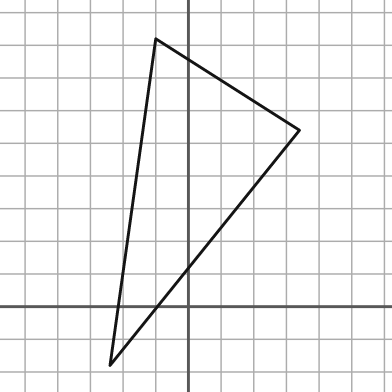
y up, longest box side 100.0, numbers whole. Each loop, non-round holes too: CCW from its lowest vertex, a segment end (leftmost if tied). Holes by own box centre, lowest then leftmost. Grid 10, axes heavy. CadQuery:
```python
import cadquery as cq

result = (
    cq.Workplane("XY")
    .moveTo(-24.0, -18.0)
    .lineTo(34.0, 54.0)
    .lineTo(-10.0, 82.0)
    .close()
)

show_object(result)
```